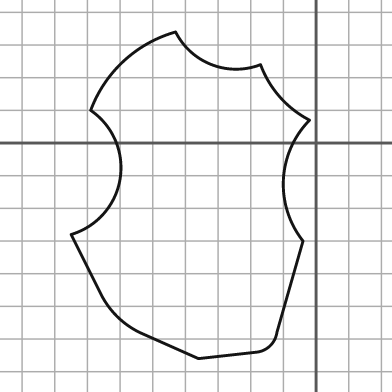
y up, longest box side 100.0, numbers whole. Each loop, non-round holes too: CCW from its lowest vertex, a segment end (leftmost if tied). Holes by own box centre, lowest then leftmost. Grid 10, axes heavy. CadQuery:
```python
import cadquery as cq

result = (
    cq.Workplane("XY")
    .moveTo(-36.0, -66.0)
    .lineTo(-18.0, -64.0)
    .threePointArc((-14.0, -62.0), (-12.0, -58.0))
    .lineTo(-4.0, -30.0)
    .threePointArc((-10.0, -11.0), (-2.0, 7.0))
    .threePointArc((-11.0, 14.0), (-17.0, 24.0))
    .threePointArc((-32.0, 24.0), (-43.0, 34.0))
    .threePointArc((-59.0, 25.0), (-69.0, 10.0))
    .threePointArc((-60.0, -11.0), (-75.0, -28.0))
    .lineTo(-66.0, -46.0)
    .threePointArc((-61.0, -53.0), (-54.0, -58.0))
    .close()
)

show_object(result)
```